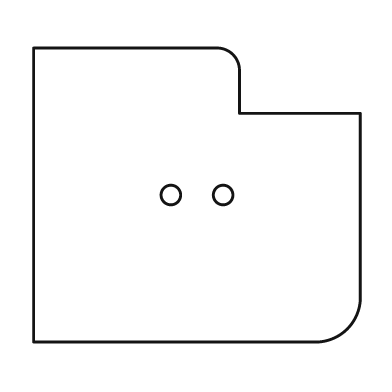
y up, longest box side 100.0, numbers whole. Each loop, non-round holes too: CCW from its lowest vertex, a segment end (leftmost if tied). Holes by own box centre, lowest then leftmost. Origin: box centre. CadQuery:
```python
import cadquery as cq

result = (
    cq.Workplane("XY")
    .moveTo(-50.0, -45.0)
    .lineTo(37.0, -45.0)
    .threePointArc((46.0, -41.0), (50.0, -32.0))
    .lineTo(50.0, 25.0)
    .lineTo(13.0, 25.0)
    .lineTo(13.0, 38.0)
    .threePointArc((11.0, 43.0), (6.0, 45.0))
    .lineTo(-50.0, 45.0)
    .close()
    .moveTo(-8.0, 0.0)
    .circle(3.0)
    .moveTo(8.0, 0.0)
    .circle(3.0)
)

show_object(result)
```